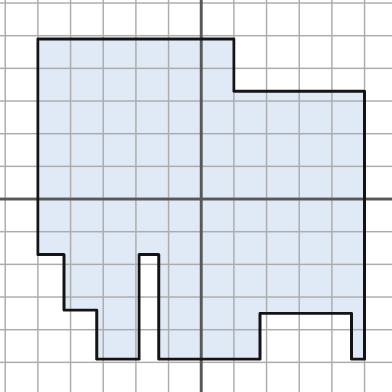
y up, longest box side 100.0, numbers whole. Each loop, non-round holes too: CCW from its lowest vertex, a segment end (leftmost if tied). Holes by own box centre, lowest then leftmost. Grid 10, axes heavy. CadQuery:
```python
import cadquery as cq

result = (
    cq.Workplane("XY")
    .moveTo(-32.0, -49.0)
    .lineTo(-19.0, -49.0)
    .lineTo(-19.0, -17.0)
    .lineTo(-13.0, -17.0)
    .lineTo(-13.0, -49.0)
    .lineTo(18.0, -49.0)
    .lineTo(18.0, -35.0)
    .lineTo(46.0, -35.0)
    .lineTo(46.0, -49.0)
    .lineTo(50.0, -49.0)
    .lineTo(50.0, 33.0)
    .lineTo(10.0, 33.0)
    .lineTo(10.0, 49.0)
    .lineTo(-50.0, 49.0)
    .lineTo(-50.0, -17.0)
    .lineTo(-42.0, -17.0)
    .lineTo(-42.0, -34.0)
    .lineTo(-32.0, -34.0)
    .close()
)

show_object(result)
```